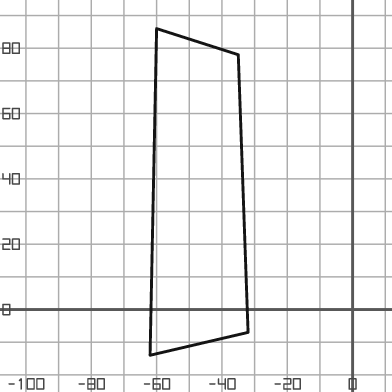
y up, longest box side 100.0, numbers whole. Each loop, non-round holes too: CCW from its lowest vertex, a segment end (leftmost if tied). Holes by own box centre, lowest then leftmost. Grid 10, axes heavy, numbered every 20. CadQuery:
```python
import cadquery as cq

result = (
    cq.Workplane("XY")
    .moveTo(-62.0, -14.0)
    .lineTo(-32.0, -7.0)
    .lineTo(-35.0, 78.0)
    .lineTo(-60.0, 86.0)
    .close()
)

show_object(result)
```